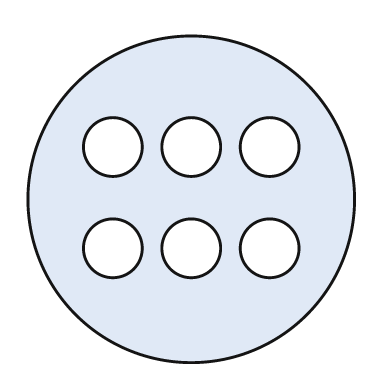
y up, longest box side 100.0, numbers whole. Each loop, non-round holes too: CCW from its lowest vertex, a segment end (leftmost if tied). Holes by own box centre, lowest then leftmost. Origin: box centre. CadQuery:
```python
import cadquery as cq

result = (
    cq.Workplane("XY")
    .moveTo(0.0, 0.0)
    .circle(50.0)
    .moveTo(-24.0, -15.0)
    .circle(9.0)
    .moveTo(0.0, -15.0)
    .circle(9.0)
    .moveTo(24.0, -15.0)
    .circle(9.0)
    .moveTo(-24.0, 16.0)
    .circle(9.0)
    .moveTo(0.0, 16.0)
    .circle(9.0)
    .moveTo(24.0, 16.0)
    .circle(9.0)
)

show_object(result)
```